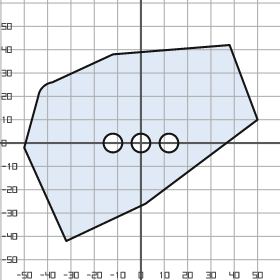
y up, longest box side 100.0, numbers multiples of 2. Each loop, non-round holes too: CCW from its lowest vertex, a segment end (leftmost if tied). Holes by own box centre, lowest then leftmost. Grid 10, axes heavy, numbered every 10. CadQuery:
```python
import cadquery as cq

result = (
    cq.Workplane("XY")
    .moveTo(-32.0, -42.0)
    .lineTo(2.0, -26.0)
    .lineTo(50.0, 10.0)
    .lineTo(38.0, 42.0)
    .lineTo(-12.0, 38.0)
    .lineTo(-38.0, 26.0)
    .threePointArc((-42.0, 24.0), (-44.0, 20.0))
    .lineTo(-50.0, -2.0)
    .close()
    .moveTo(-12.0, 0.0)
    .circle(4.0)
    .moveTo(0.0, 0.0)
    .circle(4.0)
    .moveTo(12.0, 0.0)
    .circle(4.0)
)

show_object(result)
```